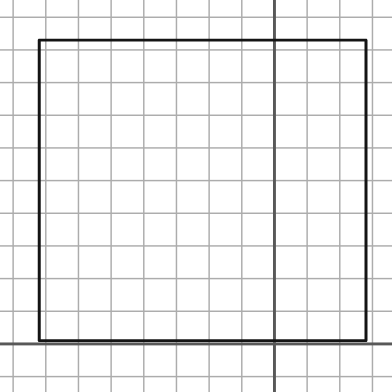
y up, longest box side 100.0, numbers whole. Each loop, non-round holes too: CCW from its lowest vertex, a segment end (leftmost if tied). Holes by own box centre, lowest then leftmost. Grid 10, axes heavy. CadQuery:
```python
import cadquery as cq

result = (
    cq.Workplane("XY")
    .moveTo(-72.0, 1.0)
    .lineTo(28.0, 1.0)
    .lineTo(28.0, 93.0)
    .lineTo(-72.0, 93.0)
    .close()
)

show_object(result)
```